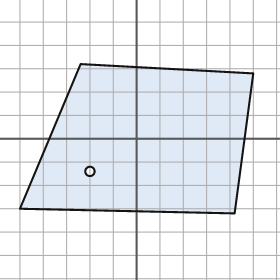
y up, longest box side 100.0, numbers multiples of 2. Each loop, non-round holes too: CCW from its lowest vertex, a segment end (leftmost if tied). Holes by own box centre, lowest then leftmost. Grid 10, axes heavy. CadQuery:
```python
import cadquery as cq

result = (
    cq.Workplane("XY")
    .moveTo(42.0, -32.0)
    .lineTo(50.0, 28.0)
    .lineTo(-24.0, 32.0)
    .lineTo(-50.0, -30.0)
    .close()
    .moveTo(-20.0, -14.0)
    .circle(2.0)
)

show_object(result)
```